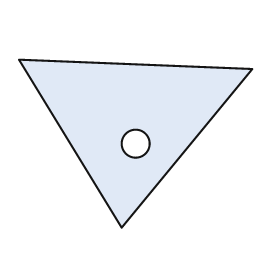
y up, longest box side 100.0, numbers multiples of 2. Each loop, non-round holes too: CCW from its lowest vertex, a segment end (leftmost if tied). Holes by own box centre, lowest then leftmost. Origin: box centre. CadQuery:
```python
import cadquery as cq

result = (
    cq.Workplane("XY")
    .moveTo(-6.0, -36.0)
    .lineTo(50.0, 32.0)
    .lineTo(-50.0, 36.0)
    .close()
    .moveTo(0.0, 0.0)
    .circle(6.0)
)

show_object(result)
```